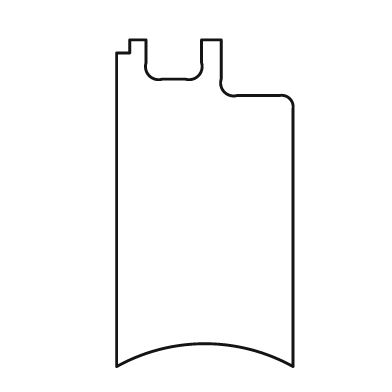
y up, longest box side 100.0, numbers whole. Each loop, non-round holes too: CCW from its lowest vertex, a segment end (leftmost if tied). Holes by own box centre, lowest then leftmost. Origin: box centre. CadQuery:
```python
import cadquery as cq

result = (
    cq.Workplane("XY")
    .moveTo(-27.0, -50.0)
    .threePointArc((0.0, -43.0), (27.0, -50.0))
    .lineTo(27.0, 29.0)
    .threePointArc((26.0, 32.0), (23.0, 33.0))
    .lineTo(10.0, 33.0)
    .threePointArc((6.0, 34.0), (5.0, 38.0))
    .lineTo(5.0, 50.0)
    .lineTo(-1.0, 50.0)
    .lineTo(-1.0, 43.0)
    .threePointArc((-2.0, 39.0), (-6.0, 38.0))
    .lineTo(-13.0, 38.0)
    .threePointArc((-17.0, 39.0), (-18.0, 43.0))
    .lineTo(-18.0, 50.0)
    .lineTo(-23.0, 50.0)
    .lineTo(-23.0, 46.0)
    .lineTo(-27.0, 46.0)
    .close()
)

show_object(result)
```